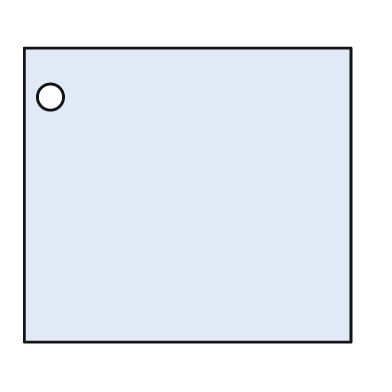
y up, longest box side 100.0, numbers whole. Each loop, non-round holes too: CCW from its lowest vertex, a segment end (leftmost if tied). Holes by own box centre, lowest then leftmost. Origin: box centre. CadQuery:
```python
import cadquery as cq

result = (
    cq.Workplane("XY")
    .moveTo(-50.0, -45.0)
    .lineTo(50.0, -45.0)
    .lineTo(50.0, 45.0)
    .lineTo(-50.0, 45.0)
    .close()
    .moveTo(-42.0, 30.0)
    .circle(4.0)
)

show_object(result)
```